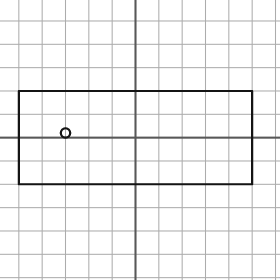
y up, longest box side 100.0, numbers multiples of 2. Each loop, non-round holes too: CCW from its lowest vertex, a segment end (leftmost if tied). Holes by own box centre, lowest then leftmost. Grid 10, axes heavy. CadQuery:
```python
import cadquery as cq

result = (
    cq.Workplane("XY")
    .moveTo(-50.0, -20.0)
    .lineTo(50.0, -20.0)
    .lineTo(50.0, 20.0)
    .lineTo(-50.0, 20.0)
    .close()
    .moveTo(-30.0, 2.0)
    .circle(2.0)
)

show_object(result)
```